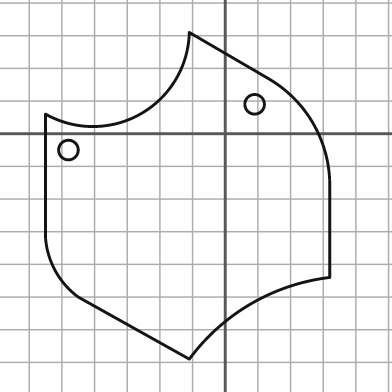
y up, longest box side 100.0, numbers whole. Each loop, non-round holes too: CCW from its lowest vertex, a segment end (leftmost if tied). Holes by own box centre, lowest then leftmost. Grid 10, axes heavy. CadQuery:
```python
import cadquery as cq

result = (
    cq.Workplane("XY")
    .moveTo(-11.0, -69.0)
    .threePointArc((8.0, -52.0), (32.0, -44.0))
    .lineTo(32.0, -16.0)
    .threePointArc((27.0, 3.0), (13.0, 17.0))
    .lineTo(-11.0, 31.0)
    .threePointArc((-26.0, 6.0), (-55.0, 6.0))
    .lineTo(-55.0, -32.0)
    .threePointArc((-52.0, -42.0), (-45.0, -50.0))
    .close()
    .moveTo(-48.0, -5.0)
    .circle(3.0)
    .moveTo(9.0, 9.0)
    .circle(3.0)
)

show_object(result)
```